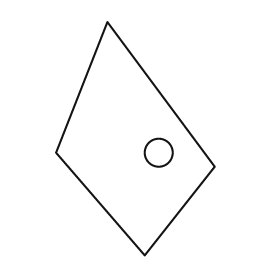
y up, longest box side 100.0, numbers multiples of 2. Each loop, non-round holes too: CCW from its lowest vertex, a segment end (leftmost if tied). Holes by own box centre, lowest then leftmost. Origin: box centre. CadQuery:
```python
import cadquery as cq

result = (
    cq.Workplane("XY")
    .moveTo(4.0, -50.0)
    .lineTo(34.0, -12.0)
    .lineTo(-12.0, 50.0)
    .lineTo(-34.0, -6.0)
    .close()
    .moveTo(10.0, -6.0)
    .circle(6.0)
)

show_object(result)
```